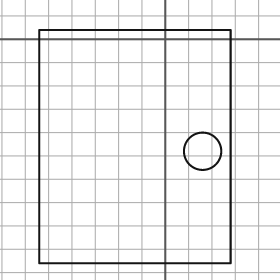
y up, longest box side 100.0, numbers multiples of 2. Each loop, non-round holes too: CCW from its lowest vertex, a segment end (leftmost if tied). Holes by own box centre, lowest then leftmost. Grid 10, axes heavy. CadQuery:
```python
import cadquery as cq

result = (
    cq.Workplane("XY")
    .moveTo(-54.0, -96.0)
    .lineTo(28.0, -96.0)
    .lineTo(28.0, 4.0)
    .lineTo(-54.0, 4.0)
    .close()
    .moveTo(16.0, -48.0)
    .circle(8.0)
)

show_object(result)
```